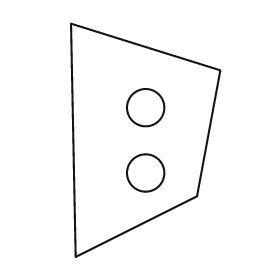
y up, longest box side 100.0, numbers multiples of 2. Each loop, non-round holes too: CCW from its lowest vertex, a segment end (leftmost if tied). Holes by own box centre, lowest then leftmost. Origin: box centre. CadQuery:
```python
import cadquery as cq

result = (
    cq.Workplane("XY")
    .moveTo(-30.0, -50.0)
    .lineTo(22.0, -24.0)
    .lineTo(32.0, 30.0)
    .lineTo(-32.0, 50.0)
    .close()
    .moveTo(0.0, -14.0)
    .circle(8.0)
    .moveTo(0.0, 14.0)
    .circle(8.0)
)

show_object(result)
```